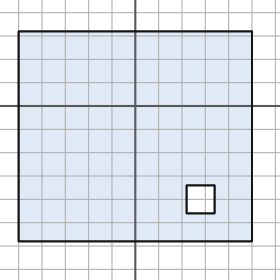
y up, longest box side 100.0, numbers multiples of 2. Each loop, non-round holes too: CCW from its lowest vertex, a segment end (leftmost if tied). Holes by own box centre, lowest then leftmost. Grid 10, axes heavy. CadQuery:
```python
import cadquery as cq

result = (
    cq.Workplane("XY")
    .moveTo(-50.0, -58.0)
    .lineTo(50.0, -58.0)
    .lineTo(50.0, 32.0)
    .lineTo(-50.0, 32.0)
    .close()
    .moveTo(22.0, -46.0)
    .lineTo(34.0, -46.0)
    .lineTo(34.0, -34.0)
    .lineTo(22.0, -34.0)
    .close()
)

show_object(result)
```